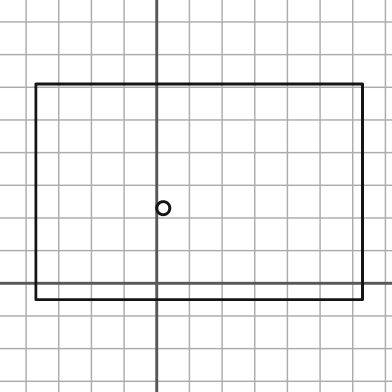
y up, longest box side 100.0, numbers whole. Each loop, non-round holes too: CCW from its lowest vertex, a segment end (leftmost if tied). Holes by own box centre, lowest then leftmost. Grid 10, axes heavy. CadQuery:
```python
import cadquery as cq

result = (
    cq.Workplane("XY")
    .moveTo(-37.0, -5.0)
    .lineTo(63.0, -5.0)
    .lineTo(63.0, 61.0)
    .lineTo(-37.0, 61.0)
    .close()
    .moveTo(2.0, 23.0)
    .circle(2.0)
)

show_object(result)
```